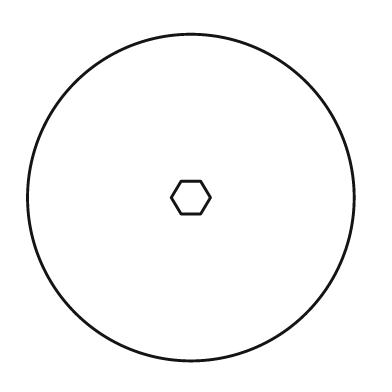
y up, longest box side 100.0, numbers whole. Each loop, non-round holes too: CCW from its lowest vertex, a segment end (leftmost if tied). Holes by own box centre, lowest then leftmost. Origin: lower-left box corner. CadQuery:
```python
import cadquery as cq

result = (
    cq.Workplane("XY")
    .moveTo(50.0, 50.0)
    .circle(50.0)
    .moveTo(47.0, 45.0)
    .lineTo(53.0, 45.0)
    .lineTo(56.0, 50.0)
    .lineTo(53.0, 55.0)
    .lineTo(47.0, 55.0)
    .lineTo(44.0, 50.0)
    .close()
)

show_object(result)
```